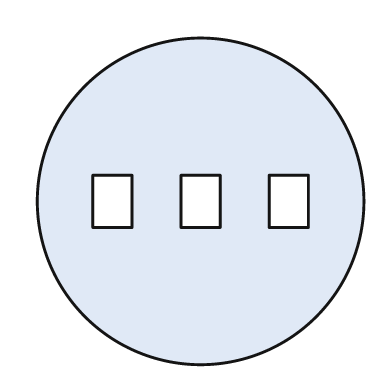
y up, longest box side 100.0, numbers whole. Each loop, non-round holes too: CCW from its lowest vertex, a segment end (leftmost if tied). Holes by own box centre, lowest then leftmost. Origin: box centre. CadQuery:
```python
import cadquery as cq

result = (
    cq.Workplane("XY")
    .moveTo(0.0, 0.0)
    .circle(50.0)
    .moveTo(-33.0, -8.0)
    .lineTo(-21.0, -8.0)
    .lineTo(-21.0, 8.0)
    .lineTo(-33.0, 8.0)
    .close()
    .moveTo(-6.0, -8.0)
    .lineTo(6.0, -8.0)
    .lineTo(6.0, 8.0)
    .lineTo(-6.0, 8.0)
    .close()
    .moveTo(21.0, -8.0)
    .lineTo(33.0, -8.0)
    .lineTo(33.0, 8.0)
    .lineTo(21.0, 8.0)
    .close()
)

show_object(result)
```